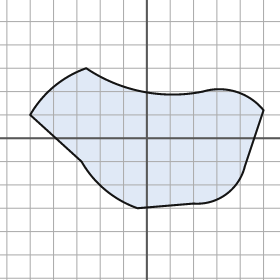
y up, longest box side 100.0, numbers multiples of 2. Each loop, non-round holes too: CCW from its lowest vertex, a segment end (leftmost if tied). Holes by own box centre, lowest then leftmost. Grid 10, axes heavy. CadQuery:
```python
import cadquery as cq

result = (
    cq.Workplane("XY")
    .moveTo(-4.0, -30.0)
    .lineTo(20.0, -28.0)
    .threePointArc((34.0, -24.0), (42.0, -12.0))
    .lineTo(50.0, 12.0)
    .threePointArc((38.0, 20.0), (24.0, 20.0))
    .threePointArc((-2.0, 20.0), (-26.0, 30.0))
    .threePointArc((-40.0, 22.0), (-50.0, 10.0))
    .lineTo(-28.0, -10.0)
    .threePointArc((-18.0, -22.0), (-4.0, -30.0))
    .close()
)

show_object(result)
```